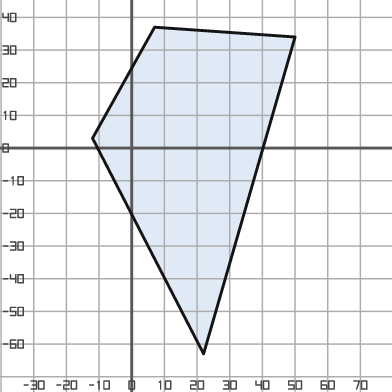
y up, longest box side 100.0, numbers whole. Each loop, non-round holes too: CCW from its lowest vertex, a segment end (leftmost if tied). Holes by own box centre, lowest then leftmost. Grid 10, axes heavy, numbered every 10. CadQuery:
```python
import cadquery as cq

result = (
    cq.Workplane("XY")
    .moveTo(22.0, -63.0)
    .lineTo(50.0, 34.0)
    .lineTo(7.0, 37.0)
    .lineTo(-12.0, 3.0)
    .close()
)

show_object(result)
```